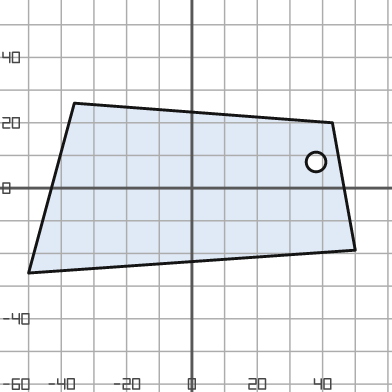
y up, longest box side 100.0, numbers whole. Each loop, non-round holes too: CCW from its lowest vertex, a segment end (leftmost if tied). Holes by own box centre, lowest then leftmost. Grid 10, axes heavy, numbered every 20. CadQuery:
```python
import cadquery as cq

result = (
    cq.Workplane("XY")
    .moveTo(-50.0, -26.0)
    .lineTo(50.0, -19.0)
    .lineTo(43.0, 20.0)
    .lineTo(-36.0, 26.0)
    .close()
    .moveTo(38.0, 8.0)
    .circle(3.0)
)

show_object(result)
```